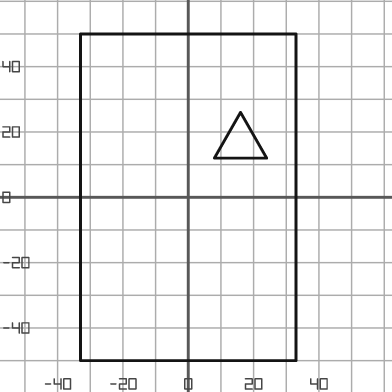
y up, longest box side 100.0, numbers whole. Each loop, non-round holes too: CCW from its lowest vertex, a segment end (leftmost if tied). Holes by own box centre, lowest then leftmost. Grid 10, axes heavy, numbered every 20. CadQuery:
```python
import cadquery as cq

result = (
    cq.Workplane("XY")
    .moveTo(-33.0, -50.0)
    .lineTo(33.0, -50.0)
    .lineTo(33.0, 50.0)
    .lineTo(-33.0, 50.0)
    .close()
    .moveTo(8.0, 12.0)
    .lineTo(24.0, 12.0)
    .lineTo(16.0, 26.0)
    .close()
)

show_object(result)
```